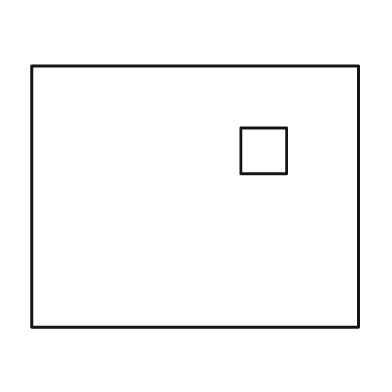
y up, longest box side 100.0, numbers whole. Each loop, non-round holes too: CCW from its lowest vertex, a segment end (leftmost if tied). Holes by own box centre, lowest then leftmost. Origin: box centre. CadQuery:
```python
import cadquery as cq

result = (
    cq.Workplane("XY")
    .moveTo(-50.0, -40.0)
    .lineTo(50.0, -40.0)
    .lineTo(50.0, 40.0)
    .lineTo(-50.0, 40.0)
    .close()
    .moveTo(14.0, 7.0)
    .lineTo(28.0, 7.0)
    .lineTo(28.0, 21.0)
    .lineTo(14.0, 21.0)
    .close()
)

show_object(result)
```